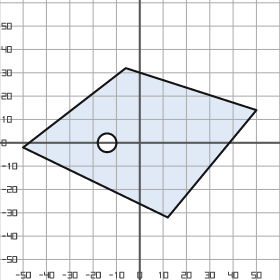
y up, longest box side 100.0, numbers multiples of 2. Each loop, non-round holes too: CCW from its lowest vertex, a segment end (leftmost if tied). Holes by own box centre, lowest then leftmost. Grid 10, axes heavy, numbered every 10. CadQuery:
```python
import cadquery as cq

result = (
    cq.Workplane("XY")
    .moveTo(12.0, -32.0)
    .lineTo(50.0, 14.0)
    .lineTo(-6.0, 32.0)
    .lineTo(-50.0, -2.0)
    .close()
    .moveTo(-14.0, 0.0)
    .circle(4.0)
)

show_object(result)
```